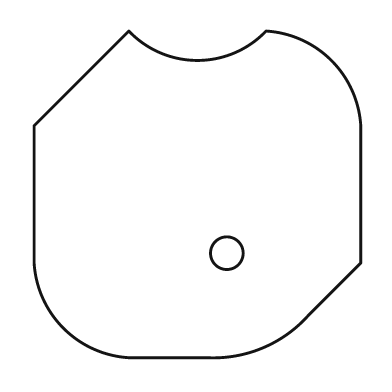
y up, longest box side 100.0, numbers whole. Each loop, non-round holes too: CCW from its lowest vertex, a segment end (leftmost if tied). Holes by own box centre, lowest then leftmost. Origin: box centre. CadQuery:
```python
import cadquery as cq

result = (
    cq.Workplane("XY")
    .moveTo(-21.0, -50.0)
    .lineTo(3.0, -50.0)
    .threePointArc((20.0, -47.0), (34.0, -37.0))
    .lineTo(50.0, -21.0)
    .lineTo(50.0, 21.0)
    .threePointArc((41.0, 41.0), (21.0, 50.0))
    .threePointArc((0.0, 41.0), (-21.0, 50.0))
    .lineTo(-50.0, 21.0)
    .lineTo(-50.0, -21.0)
    .threePointArc((-41.0, -41.0), (-21.0, -50.0))
    .close()
    .moveTo(9.0, -18.0)
    .circle(5.0)
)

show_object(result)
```